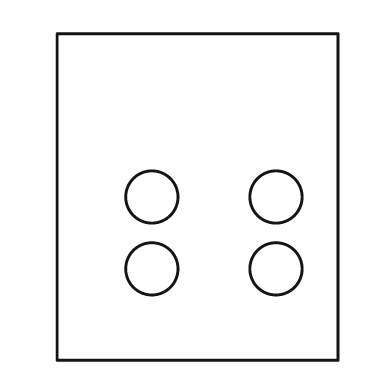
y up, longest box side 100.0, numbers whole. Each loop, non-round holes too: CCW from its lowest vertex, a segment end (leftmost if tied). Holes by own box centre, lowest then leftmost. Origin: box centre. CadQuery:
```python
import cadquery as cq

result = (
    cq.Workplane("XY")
    .moveTo(-43.0, -50.0)
    .lineTo(43.0, -50.0)
    .lineTo(43.0, 50.0)
    .lineTo(-43.0, 50.0)
    .close()
    .moveTo(-14.0, -22.0)
    .circle(8.0)
    .moveTo(24.0, -22.0)
    .circle(8.0)
    .moveTo(-14.0, 0.0)
    .circle(8.0)
    .moveTo(24.0, 0.0)
    .circle(8.0)
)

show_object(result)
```